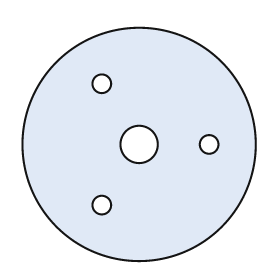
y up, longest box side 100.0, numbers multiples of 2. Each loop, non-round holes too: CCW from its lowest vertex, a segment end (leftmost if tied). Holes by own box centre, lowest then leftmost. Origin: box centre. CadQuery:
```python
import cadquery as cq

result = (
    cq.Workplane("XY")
    .moveTo(0.0, 0.0)
    .circle(50.0)
    .moveTo(-16.0, -26.0)
    .circle(4.0)
    .moveTo(0.0, 0.0)
    .circle(8.0)
    .moveTo(30.0, 0.0)
    .circle(4.0)
    .moveTo(-16.0, 26.0)
    .circle(4.0)
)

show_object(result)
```